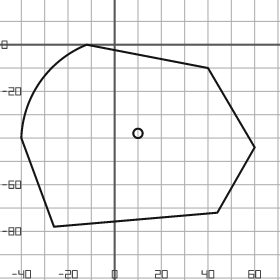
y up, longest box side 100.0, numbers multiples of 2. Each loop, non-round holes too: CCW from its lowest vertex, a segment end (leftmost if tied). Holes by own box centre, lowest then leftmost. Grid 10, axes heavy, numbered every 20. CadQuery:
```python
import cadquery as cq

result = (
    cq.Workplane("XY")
    .moveTo(-26.0, -78.0)
    .lineTo(44.0, -72.0)
    .lineTo(60.0, -44.0)
    .lineTo(40.0, -10.0)
    .lineTo(-12.0, 0.0)
    .threePointArc((-32.0, -16.0), (-40.0, -40.0))
    .close()
    .moveTo(10.0, -38.0)
    .circle(2.0)
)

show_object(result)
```